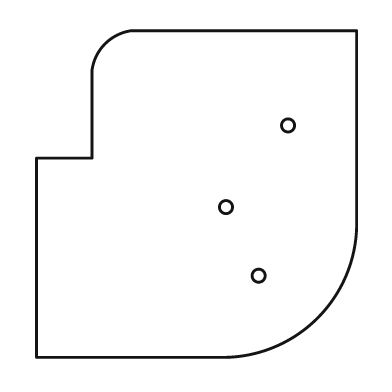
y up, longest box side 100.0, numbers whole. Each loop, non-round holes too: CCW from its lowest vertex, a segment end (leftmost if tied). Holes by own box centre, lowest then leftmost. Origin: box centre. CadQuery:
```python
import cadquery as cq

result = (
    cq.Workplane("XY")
    .moveTo(-49.0, -50.0)
    .lineTo(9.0, -50.0)
    .threePointArc((37.0, -38.0), (49.0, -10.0))
    .lineTo(49.0, 50.0)
    .lineTo(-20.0, 50.0)
    .threePointArc((-28.0, 46.0), (-32.0, 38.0))
    .lineTo(-32.0, 11.0)
    .lineTo(-49.0, 11.0)
    .close()
    .moveTo(19.0, -25.0)
    .circle(2.0)
    .moveTo(9.0, -4.0)
    .circle(2.0)
    .moveTo(28.0, 21.0)
    .circle(2.0)
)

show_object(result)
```